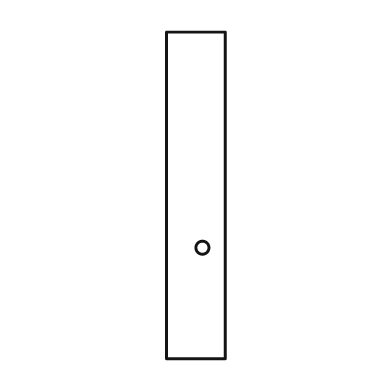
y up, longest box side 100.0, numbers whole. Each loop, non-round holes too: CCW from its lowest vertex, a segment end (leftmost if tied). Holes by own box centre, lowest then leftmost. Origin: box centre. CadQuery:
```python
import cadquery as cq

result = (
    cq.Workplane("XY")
    .moveTo(-9.0, -50.0)
    .lineTo(9.0, -50.0)
    .lineTo(9.0, 50.0)
    .lineTo(-9.0, 50.0)
    .close()
    .moveTo(2.0, -16.0)
    .circle(2.0)
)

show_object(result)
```